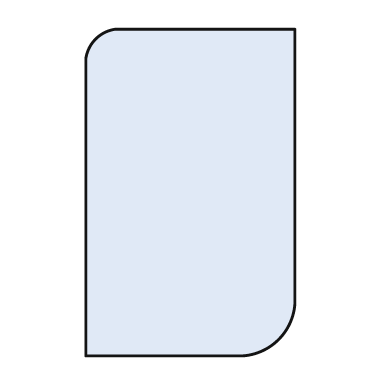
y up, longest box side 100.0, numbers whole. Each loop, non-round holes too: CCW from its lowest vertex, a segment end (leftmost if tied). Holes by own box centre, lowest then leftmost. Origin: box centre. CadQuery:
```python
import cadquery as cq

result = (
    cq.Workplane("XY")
    .moveTo(-32.0, -50.0)
    .lineTo(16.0, -50.0)
    .threePointArc((27.0, -45.0), (32.0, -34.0))
    .lineTo(32.0, 50.0)
    .lineTo(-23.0, 50.0)
    .threePointArc((-29.0, 47.0), (-32.0, 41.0))
    .close()
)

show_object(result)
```